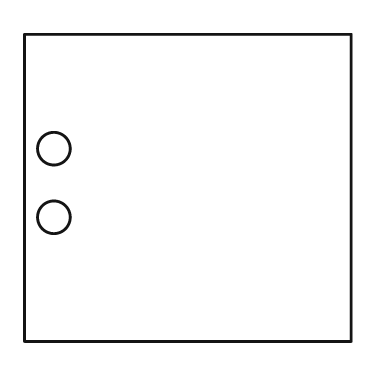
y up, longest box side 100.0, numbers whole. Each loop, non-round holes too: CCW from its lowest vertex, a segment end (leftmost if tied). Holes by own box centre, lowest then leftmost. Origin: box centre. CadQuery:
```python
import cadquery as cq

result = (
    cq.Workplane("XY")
    .moveTo(-50.0, -47.0)
    .lineTo(50.0, -47.0)
    .lineTo(50.0, 47.0)
    .lineTo(-50.0, 47.0)
    .close()
    .moveTo(-41.0, -9.0)
    .circle(5.0)
    .moveTo(-41.0, 12.0)
    .circle(5.0)
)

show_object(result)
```